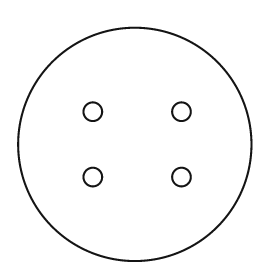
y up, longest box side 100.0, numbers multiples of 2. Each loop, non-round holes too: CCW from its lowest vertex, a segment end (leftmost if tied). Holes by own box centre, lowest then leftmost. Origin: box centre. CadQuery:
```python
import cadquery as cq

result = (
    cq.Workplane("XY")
    .moveTo(0.0, 0.0)
    .circle(50.0)
    .moveTo(-18.0, -14.0)
    .circle(4.0)
    .moveTo(20.0, -14.0)
    .circle(4.0)
    .moveTo(-18.0, 14.0)
    .circle(4.0)
    .moveTo(20.0, 14.0)
    .circle(4.0)
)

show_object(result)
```